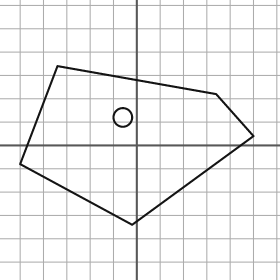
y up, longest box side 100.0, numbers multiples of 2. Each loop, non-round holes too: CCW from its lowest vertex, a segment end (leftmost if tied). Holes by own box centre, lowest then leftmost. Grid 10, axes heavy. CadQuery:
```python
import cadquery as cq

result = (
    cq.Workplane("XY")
    .moveTo(-2.0, -34.0)
    .lineTo(50.0, 4.0)
    .lineTo(34.0, 22.0)
    .lineTo(-34.0, 34.0)
    .lineTo(-50.0, -8.0)
    .close()
    .moveTo(-6.0, 12.0)
    .circle(4.0)
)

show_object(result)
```